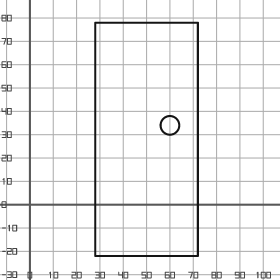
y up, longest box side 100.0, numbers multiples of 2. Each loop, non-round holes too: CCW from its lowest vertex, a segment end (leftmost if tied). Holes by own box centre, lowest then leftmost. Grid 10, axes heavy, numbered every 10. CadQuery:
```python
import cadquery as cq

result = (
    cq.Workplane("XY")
    .moveTo(28.0, -22.0)
    .lineTo(72.0, -22.0)
    .lineTo(72.0, 78.0)
    .lineTo(28.0, 78.0)
    .close()
    .moveTo(60.0, 34.0)
    .circle(4.0)
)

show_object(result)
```